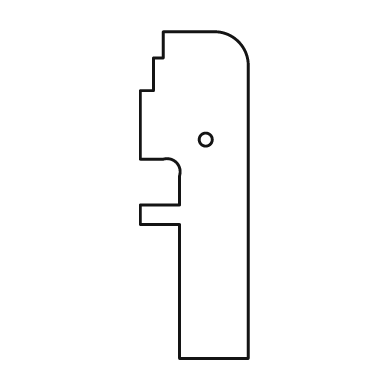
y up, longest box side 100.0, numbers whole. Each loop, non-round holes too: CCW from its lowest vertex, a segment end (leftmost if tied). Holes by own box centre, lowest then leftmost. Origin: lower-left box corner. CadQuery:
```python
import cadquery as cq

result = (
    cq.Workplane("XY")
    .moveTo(12.0, 0.0)
    .lineTo(33.0, 0.0)
    .lineTo(33.0, 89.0)
    .threePointArc((30.0, 97.0), (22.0, 100.0))
    .lineTo(7.0, 100.0)
    .lineTo(7.0, 92.0)
    .lineTo(4.0, 92.0)
    .lineTo(4.0, 82.0)
    .lineTo(0.0, 82.0)
    .lineTo(0.0, 61.0)
    .lineTo(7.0, 61.0)
    .threePointArc((11.0, 60.0), (12.0, 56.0))
    .lineTo(12.0, 47.0)
    .lineTo(0.0, 47.0)
    .lineTo(0.0, 41.0)
    .lineTo(12.0, 41.0)
    .close()
    .moveTo(20.0, 67.0)
    .circle(2.0)
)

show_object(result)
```